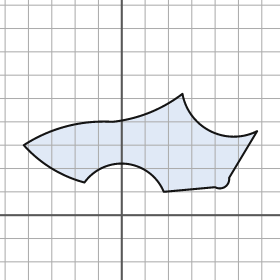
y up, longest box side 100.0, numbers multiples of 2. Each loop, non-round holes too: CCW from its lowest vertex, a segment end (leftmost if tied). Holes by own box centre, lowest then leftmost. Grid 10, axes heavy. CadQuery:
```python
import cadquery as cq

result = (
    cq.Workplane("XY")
    .moveTo(18.0, 10.0)
    .lineTo(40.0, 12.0)
    .threePointArc((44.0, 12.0), (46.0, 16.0))
    .lineTo(58.0, 36.0)
    .threePointArc((38.0, 36.0), (26.0, 52.0))
    .threePointArc((12.0, 44.0), (-4.0, 40.0))
    .threePointArc((-24.0, 38.0), (-42.0, 30.0))
    .threePointArc((-30.0, 20.0), (-16.0, 14.0))
    .threePointArc((2.0, 22.0), (18.0, 10.0))
    .close()
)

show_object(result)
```